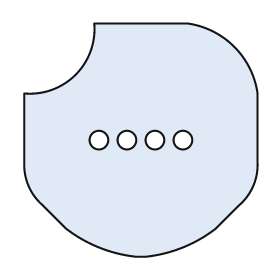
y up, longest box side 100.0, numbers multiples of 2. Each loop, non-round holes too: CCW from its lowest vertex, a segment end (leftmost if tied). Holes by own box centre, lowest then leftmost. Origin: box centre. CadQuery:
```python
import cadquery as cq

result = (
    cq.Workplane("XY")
    .moveTo(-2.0, -50.0)
    .lineTo(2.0, -50.0)
    .threePointArc((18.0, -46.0), (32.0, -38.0))
    .lineTo(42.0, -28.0)
    .threePointArc((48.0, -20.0), (50.0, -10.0))
    .lineTo(50.0, 20.0)
    .threePointArc((40.0, 40.0), (20.0, 50.0))
    .lineTo(-20.0, 50.0)
    .threePointArc((-28.0, 28.0), (-50.0, 20.0))
    .lineTo(-50.0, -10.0)
    .threePointArc((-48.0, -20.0), (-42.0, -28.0))
    .lineTo(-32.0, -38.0)
    .threePointArc((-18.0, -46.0), (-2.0, -50.0))
    .close()
    .moveTo(-18.0, 0.0)
    .circle(4.0)
    .moveTo(-6.0, 0.0)
    .circle(4.0)
    .moveTo(6.0, 0.0)
    .circle(4.0)
    .moveTo(18.0, 0.0)
    .circle(4.0)
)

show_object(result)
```